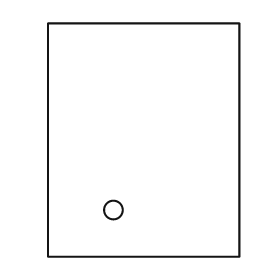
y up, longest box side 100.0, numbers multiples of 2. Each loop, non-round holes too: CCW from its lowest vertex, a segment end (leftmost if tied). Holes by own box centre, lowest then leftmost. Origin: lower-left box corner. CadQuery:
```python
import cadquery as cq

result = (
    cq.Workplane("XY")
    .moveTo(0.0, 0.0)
    .lineTo(82.0, 0.0)
    .lineTo(82.0, 100.0)
    .lineTo(0.0, 100.0)
    .close()
    .moveTo(28.0, 20.0)
    .circle(4.0)
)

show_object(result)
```